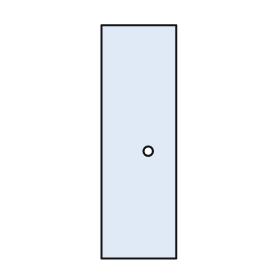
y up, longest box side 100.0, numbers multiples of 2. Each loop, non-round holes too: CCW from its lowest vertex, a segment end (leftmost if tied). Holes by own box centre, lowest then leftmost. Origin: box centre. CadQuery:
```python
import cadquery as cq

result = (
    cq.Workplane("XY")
    .moveTo(-16.0, -50.0)
    .lineTo(16.0, -50.0)
    .lineTo(16.0, 50.0)
    .lineTo(-16.0, 50.0)
    .close()
    .moveTo(4.0, -4.0)
    .circle(2.0)
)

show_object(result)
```